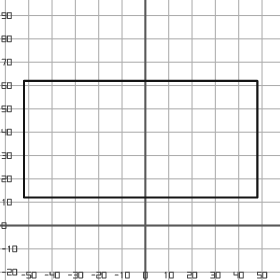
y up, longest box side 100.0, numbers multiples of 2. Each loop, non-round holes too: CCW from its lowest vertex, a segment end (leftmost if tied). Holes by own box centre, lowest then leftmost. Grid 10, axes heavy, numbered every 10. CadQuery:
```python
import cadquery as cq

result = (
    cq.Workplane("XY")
    .moveTo(-52.0, 12.0)
    .lineTo(48.0, 12.0)
    .lineTo(48.0, 62.0)
    .lineTo(-52.0, 62.0)
    .close()
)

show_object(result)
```